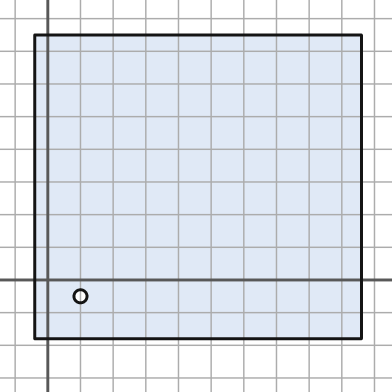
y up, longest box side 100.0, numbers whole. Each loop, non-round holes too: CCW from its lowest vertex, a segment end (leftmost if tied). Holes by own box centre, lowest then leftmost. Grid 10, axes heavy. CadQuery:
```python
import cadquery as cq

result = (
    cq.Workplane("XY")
    .moveTo(-4.0, -18.0)
    .lineTo(96.0, -18.0)
    .lineTo(96.0, 75.0)
    .lineTo(-4.0, 75.0)
    .close()
    .moveTo(10.0, -5.0)
    .circle(2.0)
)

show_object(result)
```